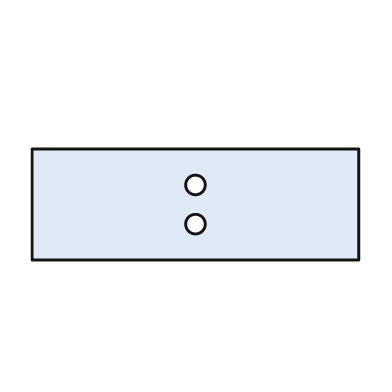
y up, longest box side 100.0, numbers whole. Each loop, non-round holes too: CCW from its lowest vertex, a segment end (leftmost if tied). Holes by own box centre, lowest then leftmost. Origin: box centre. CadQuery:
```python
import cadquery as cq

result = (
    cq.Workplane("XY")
    .moveTo(-50.0, -17.0)
    .lineTo(50.0, -17.0)
    .lineTo(50.0, 17.0)
    .lineTo(-50.0, 17.0)
    .close()
    .moveTo(0.0, -6.0)
    .circle(3.0)
    .moveTo(0.0, 6.0)
    .circle(3.0)
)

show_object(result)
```